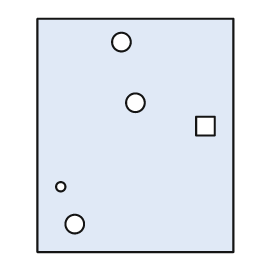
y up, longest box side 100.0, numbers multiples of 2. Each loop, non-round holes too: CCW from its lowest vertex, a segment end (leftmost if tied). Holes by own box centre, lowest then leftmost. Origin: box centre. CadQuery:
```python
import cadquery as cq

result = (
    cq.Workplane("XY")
    .moveTo(-42.0, -50.0)
    .lineTo(42.0, -50.0)
    .lineTo(42.0, 50.0)
    .lineTo(-42.0, 50.0)
    .close()
    .moveTo(-26.0, -38.0)
    .circle(4.0)
    .moveTo(-32.0, -22.0)
    .circle(2.0)
    .moveTo(26.0, 0.0)
    .lineTo(34.0, 0.0)
    .lineTo(34.0, 8.0)
    .lineTo(26.0, 8.0)
    .close()
    .moveTo(0.0, 14.0)
    .circle(4.0)
    .moveTo(-6.0, 40.0)
    .circle(4.0)
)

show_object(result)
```